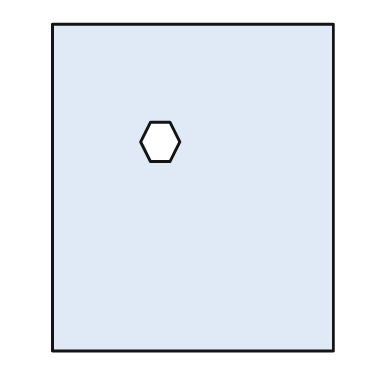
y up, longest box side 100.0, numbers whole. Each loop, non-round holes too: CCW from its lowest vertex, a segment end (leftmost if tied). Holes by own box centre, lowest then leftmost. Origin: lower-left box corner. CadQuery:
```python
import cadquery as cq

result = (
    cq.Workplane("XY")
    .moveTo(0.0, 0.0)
    .lineTo(86.0, 0.0)
    .lineTo(86.0, 100.0)
    .lineTo(0.0, 100.0)
    .close()
    .moveTo(30.0, 58.0)
    .lineTo(36.0, 58.0)
    .lineTo(39.0, 64.0)
    .lineTo(36.0, 70.0)
    .lineTo(30.0, 70.0)
    .lineTo(27.0, 64.0)
    .close()
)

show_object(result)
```